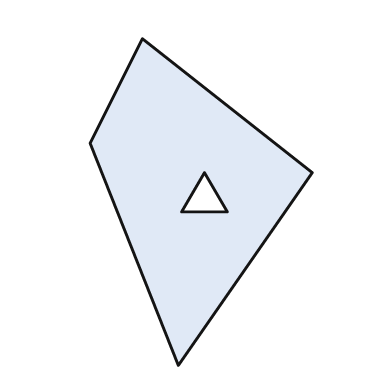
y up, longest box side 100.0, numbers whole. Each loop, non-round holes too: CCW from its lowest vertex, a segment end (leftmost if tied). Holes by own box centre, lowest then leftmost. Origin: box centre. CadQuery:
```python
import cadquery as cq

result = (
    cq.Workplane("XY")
    .moveTo(-7.0, -50.0)
    .lineTo(34.0, 9.0)
    .lineTo(-18.0, 50.0)
    .lineTo(-34.0, 18.0)
    .close()
    .moveTo(-6.0, -3.0)
    .lineTo(8.0, -3.0)
    .lineTo(1.0, 9.0)
    .close()
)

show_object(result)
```